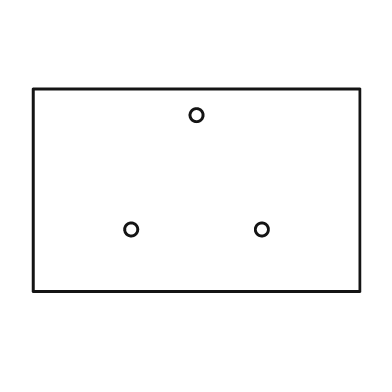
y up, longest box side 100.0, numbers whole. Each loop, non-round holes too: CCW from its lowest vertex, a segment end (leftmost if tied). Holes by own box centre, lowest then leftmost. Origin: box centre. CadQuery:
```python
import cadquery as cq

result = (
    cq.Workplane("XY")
    .moveTo(-50.0, -31.0)
    .lineTo(50.0, -31.0)
    .lineTo(50.0, 31.0)
    .lineTo(-50.0, 31.0)
    .close()
    .moveTo(-20.0, -12.0)
    .circle(2.0)
    .moveTo(20.0, -12.0)
    .circle(2.0)
    .moveTo(0.0, 23.0)
    .circle(2.0)
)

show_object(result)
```